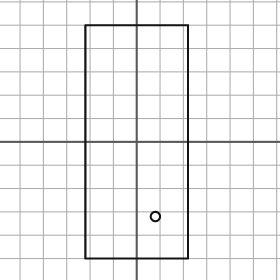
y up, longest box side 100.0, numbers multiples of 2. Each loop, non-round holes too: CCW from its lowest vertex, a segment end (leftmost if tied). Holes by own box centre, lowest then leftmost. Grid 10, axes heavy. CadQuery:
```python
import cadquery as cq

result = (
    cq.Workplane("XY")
    .moveTo(-22.0, -50.0)
    .lineTo(22.0, -50.0)
    .lineTo(22.0, 50.0)
    .lineTo(-22.0, 50.0)
    .close()
    .moveTo(8.0, -32.0)
    .circle(2.0)
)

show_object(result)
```